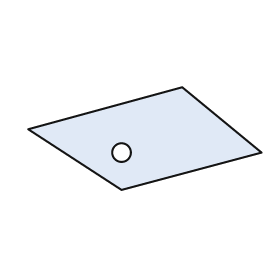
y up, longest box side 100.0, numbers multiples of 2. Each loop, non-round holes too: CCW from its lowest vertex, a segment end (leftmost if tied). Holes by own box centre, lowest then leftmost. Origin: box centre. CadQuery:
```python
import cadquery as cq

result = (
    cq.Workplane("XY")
    .moveTo(-10.0, -22.0)
    .lineTo(50.0, -6.0)
    .lineTo(16.0, 22.0)
    .lineTo(-50.0, 4.0)
    .close()
    .moveTo(-10.0, -6.0)
    .circle(4.0)
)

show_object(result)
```